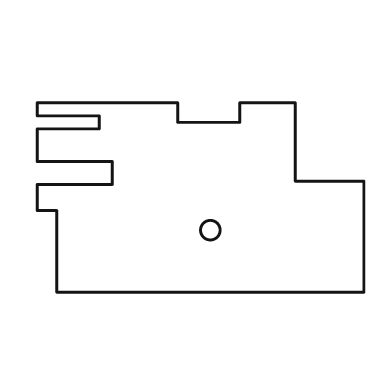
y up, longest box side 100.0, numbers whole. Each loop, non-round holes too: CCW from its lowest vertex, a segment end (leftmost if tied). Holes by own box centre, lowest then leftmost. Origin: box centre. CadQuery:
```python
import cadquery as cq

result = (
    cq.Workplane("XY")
    .moveTo(-44.0, -29.0)
    .lineTo(50.0, -29.0)
    .lineTo(50.0, 5.0)
    .lineTo(29.0, 5.0)
    .lineTo(29.0, 29.0)
    .lineTo(12.0, 29.0)
    .lineTo(12.0, 23.0)
    .lineTo(-7.0, 23.0)
    .lineTo(-7.0, 29.0)
    .lineTo(-50.0, 29.0)
    .lineTo(-50.0, 25.0)
    .lineTo(-31.0, 25.0)
    .lineTo(-31.0, 21.0)
    .lineTo(-50.0, 21.0)
    .lineTo(-50.0, 11.0)
    .lineTo(-27.0, 11.0)
    .lineTo(-27.0, 4.0)
    .lineTo(-50.0, 4.0)
    .lineTo(-50.0, -4.0)
    .lineTo(-44.0, -4.0)
    .close()
    .moveTo(3.0, -10.0)
    .circle(3.0)
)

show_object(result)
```